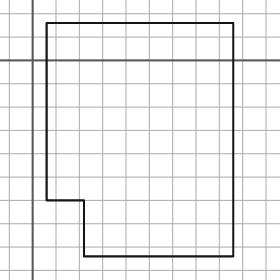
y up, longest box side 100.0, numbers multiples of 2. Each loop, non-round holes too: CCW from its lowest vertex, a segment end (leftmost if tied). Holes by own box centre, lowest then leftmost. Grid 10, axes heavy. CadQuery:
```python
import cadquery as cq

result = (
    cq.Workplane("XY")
    .moveTo(22.0, -84.0)
    .lineTo(86.0, -84.0)
    .lineTo(86.0, 16.0)
    .lineTo(6.0, 16.0)
    .lineTo(6.0, -60.0)
    .lineTo(22.0, -60.0)
    .close()
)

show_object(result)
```